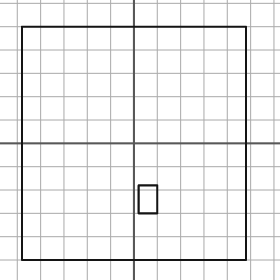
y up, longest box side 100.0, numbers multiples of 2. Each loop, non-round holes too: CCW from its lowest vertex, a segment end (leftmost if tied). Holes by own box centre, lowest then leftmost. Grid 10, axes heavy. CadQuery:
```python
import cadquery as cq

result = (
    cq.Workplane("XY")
    .moveTo(-48.0, -50.0)
    .lineTo(48.0, -50.0)
    .lineTo(48.0, 50.0)
    .lineTo(-48.0, 50.0)
    .close()
    .moveTo(2.0, -30.0)
    .lineTo(10.0, -30.0)
    .lineTo(10.0, -18.0)
    .lineTo(2.0, -18.0)
    .close()
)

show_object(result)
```